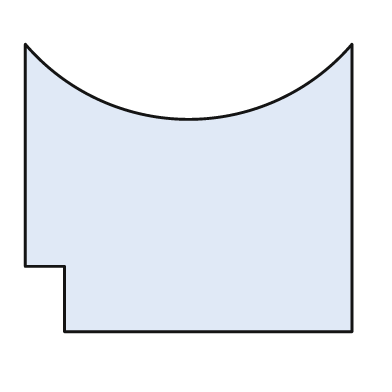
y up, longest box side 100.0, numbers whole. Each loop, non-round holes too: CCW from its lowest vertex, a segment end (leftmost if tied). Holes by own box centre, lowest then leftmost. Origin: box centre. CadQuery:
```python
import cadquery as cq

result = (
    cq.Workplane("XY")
    .moveTo(-38.0, -44.0)
    .lineTo(50.0, -44.0)
    .lineTo(50.0, 44.0)
    .threePointArc((0.0, 21.0), (-50.0, 44.0))
    .lineTo(-50.0, -24.0)
    .lineTo(-38.0, -24.0)
    .close()
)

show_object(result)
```